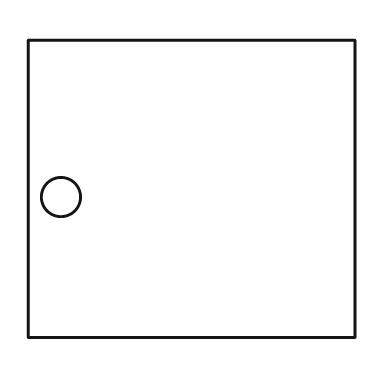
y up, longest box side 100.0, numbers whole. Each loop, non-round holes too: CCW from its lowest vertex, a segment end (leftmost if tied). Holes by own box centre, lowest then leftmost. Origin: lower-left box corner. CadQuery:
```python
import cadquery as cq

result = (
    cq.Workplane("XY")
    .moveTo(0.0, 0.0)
    .lineTo(100.0, 0.0)
    .lineTo(100.0, 91.0)
    .lineTo(0.0, 91.0)
    .close()
    .moveTo(10.0, 43.0)
    .circle(6.0)
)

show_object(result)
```